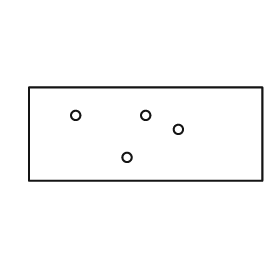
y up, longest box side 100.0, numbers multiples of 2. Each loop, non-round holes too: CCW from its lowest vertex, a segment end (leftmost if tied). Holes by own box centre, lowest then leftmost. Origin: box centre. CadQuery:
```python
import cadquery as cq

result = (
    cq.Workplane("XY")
    .moveTo(-50.0, -20.0)
    .lineTo(50.0, -20.0)
    .lineTo(50.0, 20.0)
    .lineTo(-50.0, 20.0)
    .close()
    .moveTo(-8.0, -10.0)
    .circle(2.0)
    .moveTo(14.0, 2.0)
    .circle(2.0)
    .moveTo(-30.0, 8.0)
    .circle(2.0)
    .moveTo(0.0, 8.0)
    .circle(2.0)
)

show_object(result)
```